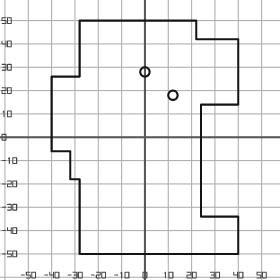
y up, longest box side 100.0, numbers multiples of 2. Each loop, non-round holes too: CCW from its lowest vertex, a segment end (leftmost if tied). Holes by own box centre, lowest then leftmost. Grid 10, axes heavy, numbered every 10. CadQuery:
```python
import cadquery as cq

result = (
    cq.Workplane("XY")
    .moveTo(-28.0, -50.0)
    .lineTo(40.0, -50.0)
    .lineTo(40.0, -34.0)
    .lineTo(24.0, -34.0)
    .lineTo(24.0, 14.0)
    .lineTo(40.0, 14.0)
    .lineTo(40.0, 42.0)
    .lineTo(22.0, 42.0)
    .lineTo(22.0, 50.0)
    .lineTo(-28.0, 50.0)
    .lineTo(-28.0, 26.0)
    .lineTo(-40.0, 26.0)
    .lineTo(-40.0, -6.0)
    .lineTo(-32.0, -6.0)
    .lineTo(-32.0, -18.0)
    .lineTo(-28.0, -18.0)
    .close()
    .moveTo(12.0, 18.0)
    .circle(2.0)
    .moveTo(0.0, 28.0)
    .circle(2.0)
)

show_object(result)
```